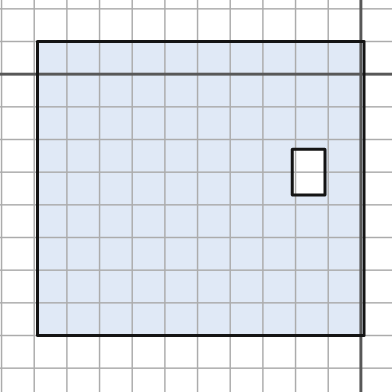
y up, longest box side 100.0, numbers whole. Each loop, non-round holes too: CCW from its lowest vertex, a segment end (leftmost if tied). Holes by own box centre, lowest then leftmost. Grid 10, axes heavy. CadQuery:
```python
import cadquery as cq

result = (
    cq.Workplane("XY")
    .moveTo(-99.0, -80.0)
    .lineTo(1.0, -80.0)
    .lineTo(1.0, 10.0)
    .lineTo(-99.0, 10.0)
    .close()
    .moveTo(-21.0, -37.0)
    .lineTo(-11.0, -37.0)
    .lineTo(-11.0, -23.0)
    .lineTo(-21.0, -23.0)
    .close()
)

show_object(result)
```